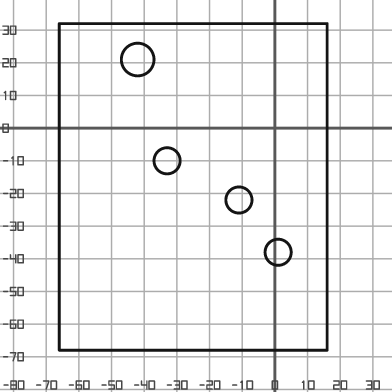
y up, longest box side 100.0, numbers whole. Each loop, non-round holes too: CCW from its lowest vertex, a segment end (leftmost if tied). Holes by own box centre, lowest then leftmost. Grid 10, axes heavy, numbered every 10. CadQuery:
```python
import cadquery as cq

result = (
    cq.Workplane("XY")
    .moveTo(-66.0, -68.0)
    .lineTo(16.0, -68.0)
    .lineTo(16.0, 32.0)
    .lineTo(-66.0, 32.0)
    .close()
    .moveTo(1.0, -38.0)
    .circle(4.0)
    .moveTo(-11.0, -22.0)
    .circle(4.0)
    .moveTo(-33.0, -10.0)
    .circle(4.0)
    .moveTo(-42.0, 21.0)
    .circle(5.0)
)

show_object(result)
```